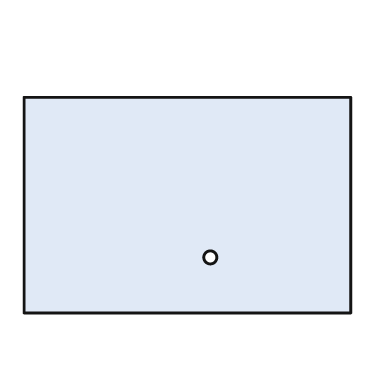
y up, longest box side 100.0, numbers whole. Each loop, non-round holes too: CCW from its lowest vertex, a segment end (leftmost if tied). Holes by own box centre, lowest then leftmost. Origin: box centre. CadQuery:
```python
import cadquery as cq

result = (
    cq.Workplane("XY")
    .moveTo(-50.0, -33.0)
    .lineTo(50.0, -33.0)
    .lineTo(50.0, 33.0)
    .lineTo(-50.0, 33.0)
    .close()
    .moveTo(7.0, -16.0)
    .circle(2.0)
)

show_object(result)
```